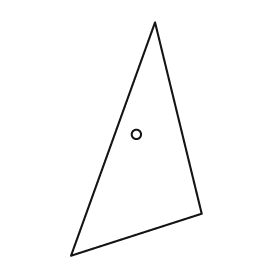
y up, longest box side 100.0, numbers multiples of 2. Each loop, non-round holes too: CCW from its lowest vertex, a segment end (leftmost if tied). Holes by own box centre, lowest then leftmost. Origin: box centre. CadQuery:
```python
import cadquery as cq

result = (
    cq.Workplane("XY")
    .moveTo(-28.0, -50.0)
    .lineTo(28.0, -32.0)
    .lineTo(8.0, 50.0)
    .close()
    .moveTo(0.0, 2.0)
    .circle(2.0)
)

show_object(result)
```